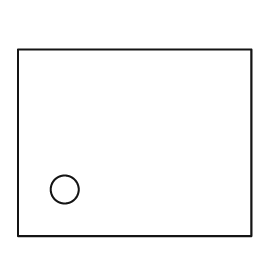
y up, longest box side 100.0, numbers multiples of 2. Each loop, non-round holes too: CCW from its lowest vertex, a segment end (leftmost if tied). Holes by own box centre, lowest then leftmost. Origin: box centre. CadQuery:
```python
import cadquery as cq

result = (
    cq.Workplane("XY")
    .moveTo(-50.0, -40.0)
    .lineTo(50.0, -40.0)
    .lineTo(50.0, 40.0)
    .lineTo(-50.0, 40.0)
    .close()
    .moveTo(-30.0, -20.0)
    .circle(6.0)
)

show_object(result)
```